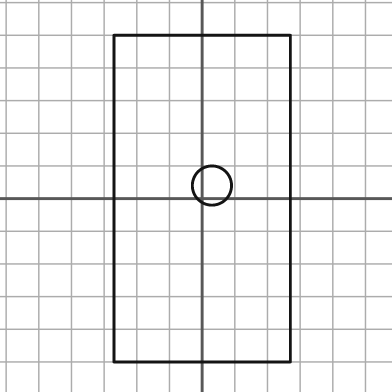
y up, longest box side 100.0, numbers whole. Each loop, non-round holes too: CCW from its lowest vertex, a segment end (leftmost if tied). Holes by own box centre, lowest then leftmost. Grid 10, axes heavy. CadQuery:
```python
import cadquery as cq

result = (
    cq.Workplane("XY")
    .moveTo(-27.0, -50.0)
    .lineTo(27.0, -50.0)
    .lineTo(27.0, 50.0)
    .lineTo(-27.0, 50.0)
    .close()
    .moveTo(3.0, 4.0)
    .circle(6.0)
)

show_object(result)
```